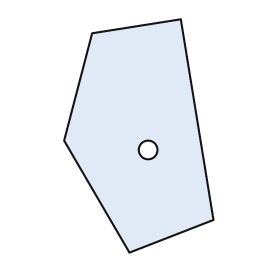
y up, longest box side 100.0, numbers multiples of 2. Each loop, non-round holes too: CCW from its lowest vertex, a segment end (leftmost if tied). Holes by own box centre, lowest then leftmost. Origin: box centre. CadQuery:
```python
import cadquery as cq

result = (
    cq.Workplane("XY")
    .moveTo(-4.0, -50.0)
    .lineTo(32.0, -36.0)
    .lineTo(18.0, 50.0)
    .lineTo(-20.0, 44.0)
    .lineTo(-32.0, -2.0)
    .close()
    .moveTo(4.0, -6.0)
    .circle(4.0)
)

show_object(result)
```